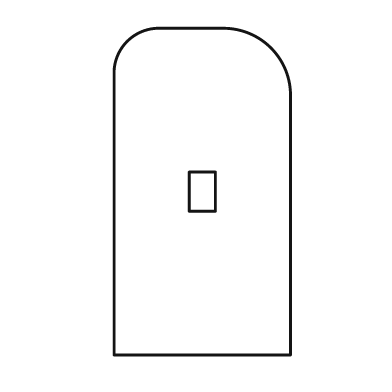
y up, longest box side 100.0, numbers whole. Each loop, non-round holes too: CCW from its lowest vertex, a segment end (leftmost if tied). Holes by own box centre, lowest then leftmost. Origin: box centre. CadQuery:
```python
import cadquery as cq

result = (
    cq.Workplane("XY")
    .moveTo(-27.0, -50.0)
    .lineTo(27.0, -50.0)
    .lineTo(27.0, 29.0)
    .threePointArc((21.0, 44.0), (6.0, 50.0))
    .lineTo(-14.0, 50.0)
    .threePointArc((-23.0, 46.0), (-27.0, 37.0))
    .close()
    .moveTo(-4.0, -6.0)
    .lineTo(4.0, -6.0)
    .lineTo(4.0, 6.0)
    .lineTo(-4.0, 6.0)
    .close()
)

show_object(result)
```